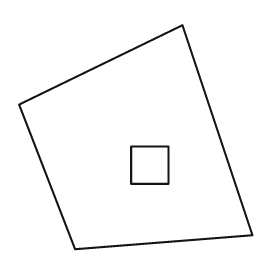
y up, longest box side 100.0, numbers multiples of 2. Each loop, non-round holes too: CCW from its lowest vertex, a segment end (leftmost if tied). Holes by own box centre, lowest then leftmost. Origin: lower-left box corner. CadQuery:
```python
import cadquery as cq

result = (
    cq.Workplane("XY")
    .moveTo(24.0, 0.0)
    .lineTo(100.0, 6.0)
    .lineTo(70.0, 96.0)
    .lineTo(0.0, 62.0)
    .close()
    .moveTo(48.0, 28.0)
    .lineTo(64.0, 28.0)
    .lineTo(64.0, 44.0)
    .lineTo(48.0, 44.0)
    .close()
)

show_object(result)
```